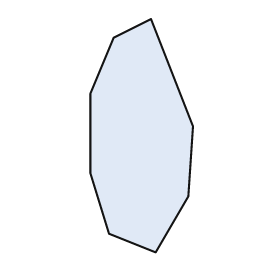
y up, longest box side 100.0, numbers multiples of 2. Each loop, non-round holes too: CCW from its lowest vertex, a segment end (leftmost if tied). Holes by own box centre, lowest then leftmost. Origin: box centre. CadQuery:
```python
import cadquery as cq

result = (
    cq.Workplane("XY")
    .moveTo(6.0, -50.0)
    .lineTo(20.0, -26.0)
    .lineTo(22.0, 4.0)
    .lineTo(4.0, 50.0)
    .lineTo(-12.0, 42.0)
    .lineTo(-22.0, 18.0)
    .lineTo(-22.0, -16.0)
    .lineTo(-14.0, -42.0)
    .close()
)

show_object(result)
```